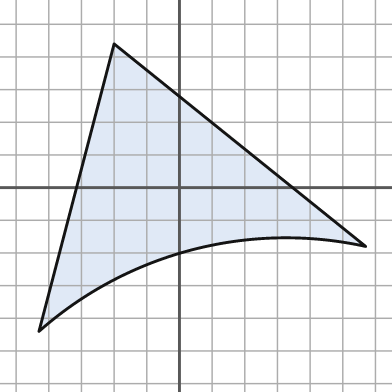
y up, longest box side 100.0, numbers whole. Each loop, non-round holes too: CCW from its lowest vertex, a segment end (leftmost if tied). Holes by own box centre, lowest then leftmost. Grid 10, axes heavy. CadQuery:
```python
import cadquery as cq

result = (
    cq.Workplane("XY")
    .moveTo(-43.0, -44.0)
    .threePointArc((4.0, -19.0), (57.0, -18.0))
    .lineTo(-20.0, 44.0)
    .close()
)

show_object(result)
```